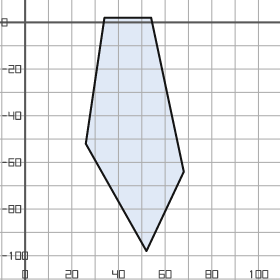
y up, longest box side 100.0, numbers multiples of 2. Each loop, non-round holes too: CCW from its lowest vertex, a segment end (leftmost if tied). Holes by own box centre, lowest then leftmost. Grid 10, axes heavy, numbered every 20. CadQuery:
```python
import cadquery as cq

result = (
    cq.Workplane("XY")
    .moveTo(52.0, -98.0)
    .lineTo(68.0, -64.0)
    .lineTo(54.0, 2.0)
    .lineTo(34.0, 2.0)
    .lineTo(26.0, -52.0)
    .close()
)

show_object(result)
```